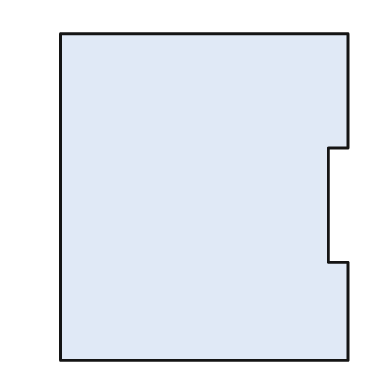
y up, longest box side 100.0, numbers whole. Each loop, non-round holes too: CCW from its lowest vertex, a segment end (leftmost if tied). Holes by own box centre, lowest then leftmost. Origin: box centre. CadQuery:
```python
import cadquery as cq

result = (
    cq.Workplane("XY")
    .moveTo(-44.0, -50.0)
    .lineTo(44.0, -50.0)
    .lineTo(44.0, -20.0)
    .lineTo(38.0, -20.0)
    .lineTo(38.0, 15.0)
    .lineTo(44.0, 15.0)
    .lineTo(44.0, 50.0)
    .lineTo(-44.0, 50.0)
    .close()
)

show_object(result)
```